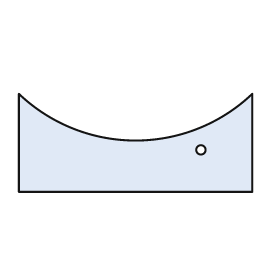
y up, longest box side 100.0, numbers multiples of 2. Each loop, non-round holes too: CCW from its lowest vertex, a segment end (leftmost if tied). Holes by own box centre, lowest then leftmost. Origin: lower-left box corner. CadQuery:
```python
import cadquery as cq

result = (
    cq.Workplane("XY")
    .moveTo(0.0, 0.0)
    .lineTo(100.0, 0.0)
    .lineTo(100.0, 42.0)
    .threePointArc((50.0, 22.0), (0.0, 42.0))
    .close()
    .moveTo(78.0, 18.0)
    .circle(2.0)
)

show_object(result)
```